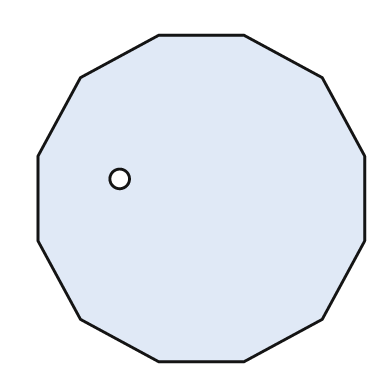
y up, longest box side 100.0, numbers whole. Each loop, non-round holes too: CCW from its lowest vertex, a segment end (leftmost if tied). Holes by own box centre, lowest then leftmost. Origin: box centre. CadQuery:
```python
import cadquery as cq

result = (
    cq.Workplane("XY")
    .moveTo(-13.0, -50.0)
    .lineTo(13.0, -50.0)
    .lineTo(37.0, -37.0)
    .lineTo(50.0, -13.0)
    .lineTo(50.0, 13.0)
    .lineTo(37.0, 37.0)
    .lineTo(13.0, 50.0)
    .lineTo(-13.0, 50.0)
    .lineTo(-37.0, 37.0)
    .lineTo(-50.0, 13.0)
    .lineTo(-50.0, -13.0)
    .lineTo(-37.0, -37.0)
    .close()
    .moveTo(-25.0, 6.0)
    .circle(3.0)
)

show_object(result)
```